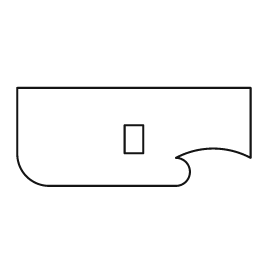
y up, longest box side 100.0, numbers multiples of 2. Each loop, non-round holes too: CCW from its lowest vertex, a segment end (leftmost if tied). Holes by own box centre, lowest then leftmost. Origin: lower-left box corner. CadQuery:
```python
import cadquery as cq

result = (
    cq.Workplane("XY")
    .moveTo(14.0, 0.0)
    .lineTo(68.0, 0.0)
    .threePointArc((74.0, 6.0), (68.0, 12.0))
    .threePointArc((84.0, 16.0), (100.0, 12.0))
    .lineTo(100.0, 42.0)
    .lineTo(0.0, 42.0)
    .lineTo(0.0, 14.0)
    .threePointArc((4.0, 4.0), (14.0, 0.0))
    .close()
    .moveTo(46.0, 14.0)
    .lineTo(54.0, 14.0)
    .lineTo(54.0, 26.0)
    .lineTo(46.0, 26.0)
    .close()
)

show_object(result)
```